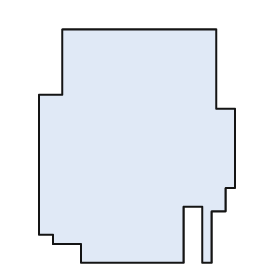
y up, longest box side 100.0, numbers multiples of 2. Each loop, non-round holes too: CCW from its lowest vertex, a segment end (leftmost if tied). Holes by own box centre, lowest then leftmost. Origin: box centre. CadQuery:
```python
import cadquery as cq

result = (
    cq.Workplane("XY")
    .moveTo(-24.0, -50.0)
    .lineTo(20.0, -50.0)
    .lineTo(20.0, -26.0)
    .lineTo(28.0, -26.0)
    .lineTo(28.0, -50.0)
    .lineTo(32.0, -50.0)
    .lineTo(32.0, -28.0)
    .lineTo(38.0, -28.0)
    .lineTo(38.0, -18.0)
    .lineTo(42.0, -18.0)
    .lineTo(42.0, 16.0)
    .lineTo(34.0, 16.0)
    .lineTo(34.0, 50.0)
    .lineTo(-32.0, 50.0)
    .lineTo(-32.0, 22.0)
    .lineTo(-42.0, 22.0)
    .lineTo(-42.0, -38.0)
    .lineTo(-36.0, -38.0)
    .lineTo(-36.0, -42.0)
    .lineTo(-24.0, -42.0)
    .close()
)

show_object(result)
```